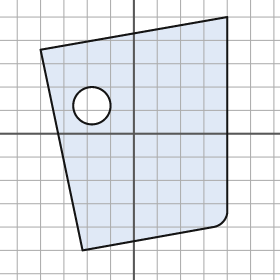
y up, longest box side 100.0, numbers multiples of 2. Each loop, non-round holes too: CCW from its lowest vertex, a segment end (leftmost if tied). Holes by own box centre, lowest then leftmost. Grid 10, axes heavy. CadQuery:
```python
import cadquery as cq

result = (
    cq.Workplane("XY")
    .moveTo(-22.0, -50.0)
    .lineTo(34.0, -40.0)
    .threePointArc((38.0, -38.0), (40.0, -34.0))
    .lineTo(40.0, 50.0)
    .lineTo(-40.0, 36.0)
    .close()
    .moveTo(-18.0, 12.0)
    .circle(8.0)
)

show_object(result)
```